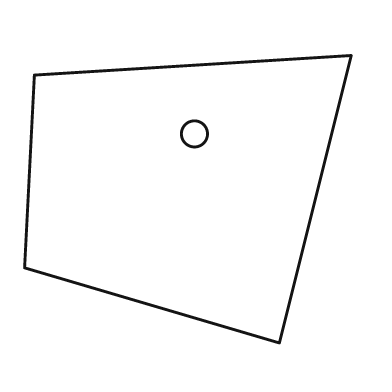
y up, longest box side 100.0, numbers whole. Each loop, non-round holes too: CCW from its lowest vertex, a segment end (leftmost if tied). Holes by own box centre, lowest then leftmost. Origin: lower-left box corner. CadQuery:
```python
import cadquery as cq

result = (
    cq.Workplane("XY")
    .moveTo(78.0, 0.0)
    .lineTo(100.0, 88.0)
    .lineTo(3.0, 82.0)
    .lineTo(0.0, 23.0)
    .close()
    .moveTo(52.0, 64.0)
    .circle(4.0)
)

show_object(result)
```